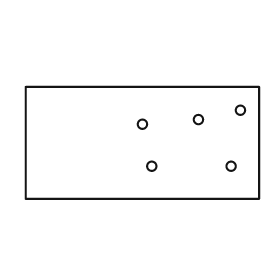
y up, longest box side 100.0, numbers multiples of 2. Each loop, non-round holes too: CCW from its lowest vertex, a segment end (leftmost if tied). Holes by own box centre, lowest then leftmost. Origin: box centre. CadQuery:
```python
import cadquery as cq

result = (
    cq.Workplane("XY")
    .moveTo(-50.0, -24.0)
    .lineTo(50.0, -24.0)
    .lineTo(50.0, 24.0)
    .lineTo(-50.0, 24.0)
    .close()
    .moveTo(4.0, -10.0)
    .circle(2.0)
    .moveTo(38.0, -10.0)
    .circle(2.0)
    .moveTo(0.0, 8.0)
    .circle(2.0)
    .moveTo(24.0, 10.0)
    .circle(2.0)
    .moveTo(42.0, 14.0)
    .circle(2.0)
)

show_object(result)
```